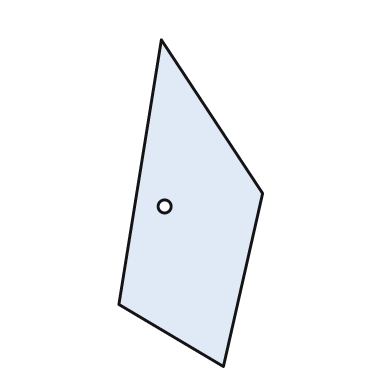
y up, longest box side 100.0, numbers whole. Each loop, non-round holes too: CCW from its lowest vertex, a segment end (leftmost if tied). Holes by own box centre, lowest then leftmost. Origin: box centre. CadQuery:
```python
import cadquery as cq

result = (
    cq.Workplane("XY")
    .moveTo(10.0, -50.0)
    .lineTo(22.0, 3.0)
    .lineTo(-9.0, 50.0)
    .lineTo(-22.0, -31.0)
    .close()
    .moveTo(-8.0, -1.0)
    .circle(2.0)
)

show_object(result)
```